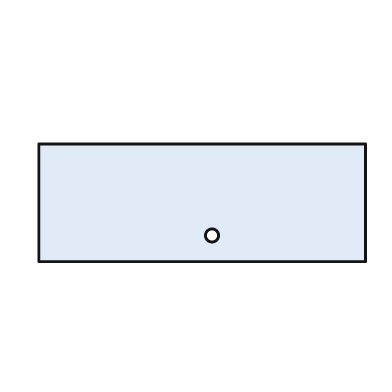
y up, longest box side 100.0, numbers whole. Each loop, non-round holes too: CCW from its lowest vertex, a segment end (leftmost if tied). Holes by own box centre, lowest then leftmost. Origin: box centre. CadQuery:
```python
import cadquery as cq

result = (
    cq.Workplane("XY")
    .moveTo(-50.0, -18.0)
    .lineTo(50.0, -18.0)
    .lineTo(50.0, 18.0)
    .lineTo(-50.0, 18.0)
    .close()
    .moveTo(3.0, -10.0)
    .circle(2.0)
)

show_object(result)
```